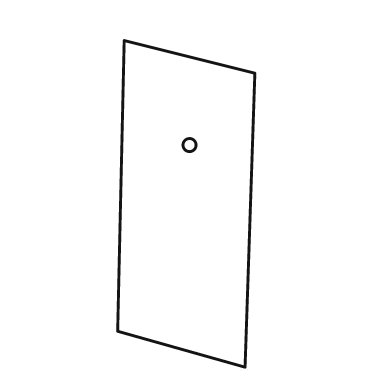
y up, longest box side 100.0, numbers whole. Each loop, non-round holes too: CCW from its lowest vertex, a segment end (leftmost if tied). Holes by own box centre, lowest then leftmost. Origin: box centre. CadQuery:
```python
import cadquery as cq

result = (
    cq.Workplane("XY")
    .moveTo(18.0, -50.0)
    .lineTo(21.0, 40.0)
    .lineTo(-19.0, 50.0)
    .lineTo(-21.0, -39.0)
    .close()
    .moveTo(1.0, 18.0)
    .circle(2.0)
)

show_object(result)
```